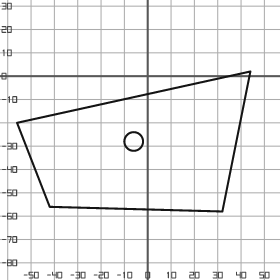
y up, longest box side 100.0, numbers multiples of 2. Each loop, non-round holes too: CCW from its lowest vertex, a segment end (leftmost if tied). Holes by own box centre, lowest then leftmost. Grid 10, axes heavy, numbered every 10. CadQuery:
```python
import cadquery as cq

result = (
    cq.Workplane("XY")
    .moveTo(32.0, -58.0)
    .lineTo(44.0, 2.0)
    .lineTo(-56.0, -20.0)
    .lineTo(-42.0, -56.0)
    .close()
    .moveTo(-6.0, -28.0)
    .circle(4.0)
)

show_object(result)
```